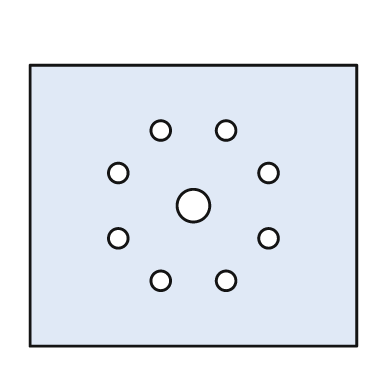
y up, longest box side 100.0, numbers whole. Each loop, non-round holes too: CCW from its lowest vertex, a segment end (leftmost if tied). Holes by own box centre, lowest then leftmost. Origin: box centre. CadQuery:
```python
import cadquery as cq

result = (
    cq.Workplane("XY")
    .moveTo(-50.0, -43.0)
    .lineTo(50.0, -43.0)
    .lineTo(50.0, 43.0)
    .lineTo(-50.0, 43.0)
    .close()
    .moveTo(-10.0, -23.0)
    .circle(3.0)
    .moveTo(10.0, -23.0)
    .circle(3.0)
    .moveTo(-23.0, -10.0)
    .circle(3.0)
    .moveTo(23.0, -10.0)
    .circle(3.0)
    .moveTo(0.0, 0.0)
    .circle(5.0)
    .moveTo(-23.0, 10.0)
    .circle(3.0)
    .moveTo(23.0, 10.0)
    .circle(3.0)
    .moveTo(-10.0, 23.0)
    .circle(3.0)
    .moveTo(10.0, 23.0)
    .circle(3.0)
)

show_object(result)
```